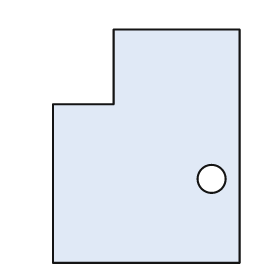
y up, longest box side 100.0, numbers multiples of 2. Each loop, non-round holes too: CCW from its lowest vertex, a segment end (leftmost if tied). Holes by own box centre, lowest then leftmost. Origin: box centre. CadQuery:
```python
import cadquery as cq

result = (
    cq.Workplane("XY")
    .moveTo(-40.0, -50.0)
    .lineTo(40.0, -50.0)
    .lineTo(40.0, 50.0)
    .lineTo(-14.0, 50.0)
    .lineTo(-14.0, 18.0)
    .lineTo(-40.0, 18.0)
    .close()
    .moveTo(28.0, -14.0)
    .circle(6.0)
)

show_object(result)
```